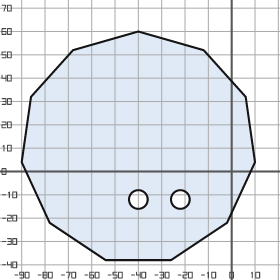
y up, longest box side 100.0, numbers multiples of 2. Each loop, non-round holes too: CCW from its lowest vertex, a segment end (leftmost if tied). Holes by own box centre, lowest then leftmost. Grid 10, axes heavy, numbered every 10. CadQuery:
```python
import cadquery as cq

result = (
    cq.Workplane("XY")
    .moveTo(-54.0, -38.0)
    .lineTo(-26.0, -38.0)
    .lineTo(-2.0, -22.0)
    .lineTo(10.0, 4.0)
    .lineTo(6.0, 32.0)
    .lineTo(-12.0, 52.0)
    .lineTo(-40.0, 60.0)
    .lineTo(-68.0, 52.0)
    .lineTo(-86.0, 32.0)
    .lineTo(-90.0, 4.0)
    .lineTo(-78.0, -22.0)
    .close()
    .moveTo(-40.0, -12.0)
    .circle(4.0)
    .moveTo(-22.0, -12.0)
    .circle(4.0)
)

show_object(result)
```